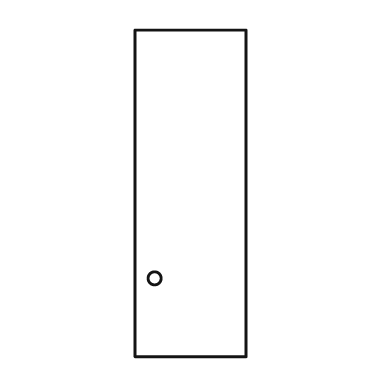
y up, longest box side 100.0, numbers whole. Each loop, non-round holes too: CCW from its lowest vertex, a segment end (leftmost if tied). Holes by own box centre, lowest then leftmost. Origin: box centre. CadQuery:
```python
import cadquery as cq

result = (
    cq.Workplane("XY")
    .moveTo(-17.0, -50.0)
    .lineTo(17.0, -50.0)
    .lineTo(17.0, 50.0)
    .lineTo(-17.0, 50.0)
    .close()
    .moveTo(-11.0, -26.0)
    .circle(2.0)
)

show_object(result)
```